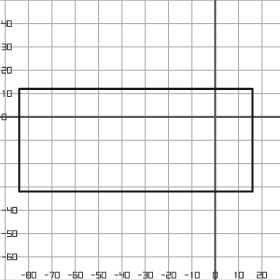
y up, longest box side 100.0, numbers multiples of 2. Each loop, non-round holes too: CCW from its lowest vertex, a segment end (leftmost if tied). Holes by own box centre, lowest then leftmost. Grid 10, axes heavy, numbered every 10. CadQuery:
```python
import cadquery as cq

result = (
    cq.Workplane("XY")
    .moveTo(-84.0, -32.0)
    .lineTo(16.0, -32.0)
    .lineTo(16.0, 12.0)
    .lineTo(-84.0, 12.0)
    .close()
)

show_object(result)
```